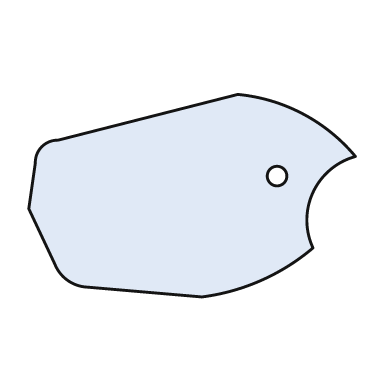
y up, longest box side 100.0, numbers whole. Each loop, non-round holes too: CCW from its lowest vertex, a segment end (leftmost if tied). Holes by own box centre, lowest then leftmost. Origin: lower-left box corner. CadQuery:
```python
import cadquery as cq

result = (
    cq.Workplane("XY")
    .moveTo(53.0, 0.0)
    .threePointArc((71.0, 5.0), (87.0, 15.0))
    .threePointArc((87.0, 32.0), (100.0, 43.0))
    .threePointArc((84.0, 56.0), (64.0, 62.0))
    .lineTo(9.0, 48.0)
    .threePointArc((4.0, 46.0), (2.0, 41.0))
    .lineTo(0.0, 27.0)
    .lineTo(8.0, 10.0)
    .threePointArc((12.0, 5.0), (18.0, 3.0))
    .close()
    .moveTo(76.0, 37.0)
    .circle(3.0)
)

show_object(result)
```